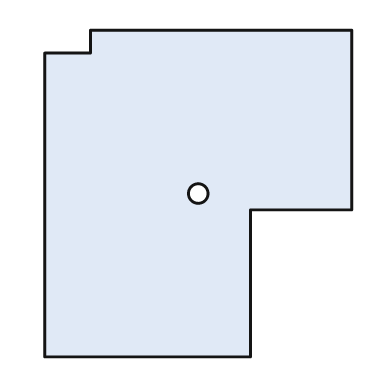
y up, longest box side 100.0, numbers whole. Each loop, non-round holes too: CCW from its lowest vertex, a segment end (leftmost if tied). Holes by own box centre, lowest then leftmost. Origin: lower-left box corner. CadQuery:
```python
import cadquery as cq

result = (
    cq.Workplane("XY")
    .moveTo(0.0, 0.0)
    .lineTo(63.0, 0.0)
    .lineTo(63.0, 45.0)
    .lineTo(94.0, 45.0)
    .lineTo(94.0, 100.0)
    .lineTo(14.0, 100.0)
    .lineTo(14.0, 93.0)
    .lineTo(0.0, 93.0)
    .close()
    .moveTo(47.0, 50.0)
    .circle(3.0)
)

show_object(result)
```